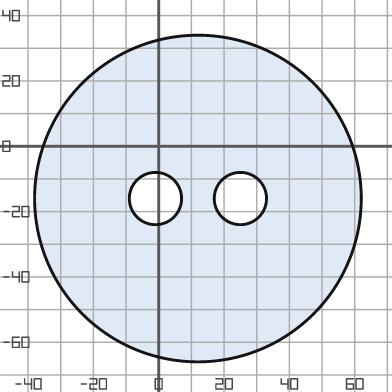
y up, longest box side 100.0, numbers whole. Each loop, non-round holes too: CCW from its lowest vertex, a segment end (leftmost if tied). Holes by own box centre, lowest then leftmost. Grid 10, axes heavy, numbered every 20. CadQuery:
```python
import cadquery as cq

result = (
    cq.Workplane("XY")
    .moveTo(12.0, -16.0)
    .circle(50.0)
    .moveTo(-1.0, -16.0)
    .circle(8.0)
    .moveTo(25.0, -16.0)
    .circle(8.0)
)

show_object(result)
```